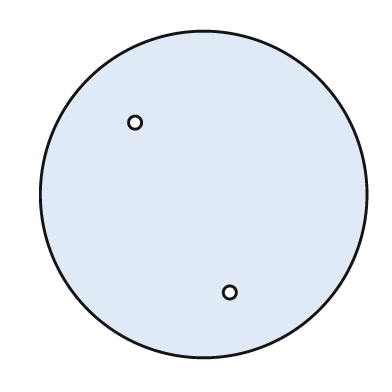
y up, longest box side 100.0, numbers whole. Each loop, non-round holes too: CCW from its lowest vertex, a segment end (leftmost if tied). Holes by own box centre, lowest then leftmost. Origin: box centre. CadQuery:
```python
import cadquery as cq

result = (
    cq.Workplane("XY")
    .moveTo(0.0, 0.0)
    .circle(50.0)
    .moveTo(8.0, -30.0)
    .circle(2.0)
    .moveTo(-21.0, 22.0)
    .circle(2.0)
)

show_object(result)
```